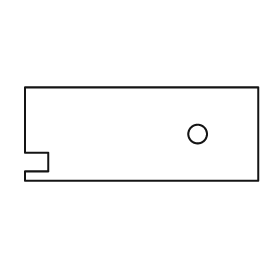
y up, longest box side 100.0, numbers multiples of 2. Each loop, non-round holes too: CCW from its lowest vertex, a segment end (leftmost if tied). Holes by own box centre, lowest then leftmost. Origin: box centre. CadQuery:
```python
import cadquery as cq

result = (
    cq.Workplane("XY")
    .moveTo(-50.0, -20.0)
    .lineTo(50.0, -20.0)
    .lineTo(50.0, 20.0)
    .lineTo(-50.0, 20.0)
    .lineTo(-50.0, -8.0)
    .lineTo(-40.0, -8.0)
    .lineTo(-40.0, -16.0)
    .lineTo(-50.0, -16.0)
    .close()
    .moveTo(24.0, 0.0)
    .circle(4.0)
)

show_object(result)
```